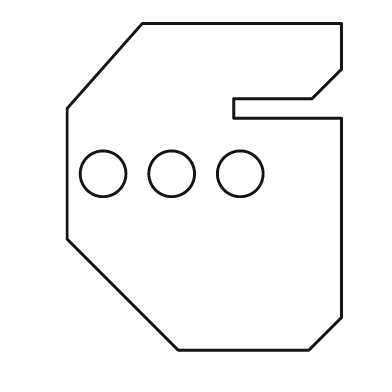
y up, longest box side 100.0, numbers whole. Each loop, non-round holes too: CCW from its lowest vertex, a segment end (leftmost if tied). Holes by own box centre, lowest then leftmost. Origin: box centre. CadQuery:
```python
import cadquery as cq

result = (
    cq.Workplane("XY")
    .moveTo(-8.0, -50.0)
    .lineTo(32.0, -50.0)
    .lineTo(42.0, -40.0)
    .lineTo(42.0, 21.0)
    .lineTo(9.0, 21.0)
    .lineTo(9.0, 27.0)
    .lineTo(33.0, 27.0)
    .lineTo(42.0, 36.0)
    .lineTo(42.0, 50.0)
    .lineTo(-19.0, 50.0)
    .lineTo(-42.0, 24.0)
    .lineTo(-42.0, -16.0)
    .close()
    .moveTo(-31.0, 4.0)
    .circle(7.0)
    .moveTo(-10.0, 4.0)
    .circle(7.0)
    .moveTo(11.0, 4.0)
    .circle(7.0)
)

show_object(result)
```